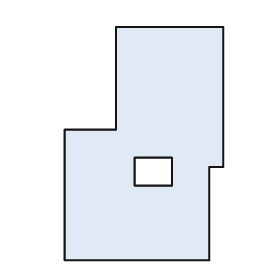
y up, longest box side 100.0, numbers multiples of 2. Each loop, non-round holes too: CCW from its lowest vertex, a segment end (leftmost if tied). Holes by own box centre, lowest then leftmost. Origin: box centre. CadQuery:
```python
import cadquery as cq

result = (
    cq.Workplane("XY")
    .moveTo(-34.0, -50.0)
    .lineTo(28.0, -50.0)
    .lineTo(28.0, -10.0)
    .lineTo(34.0, -10.0)
    .lineTo(34.0, 50.0)
    .lineTo(-12.0, 50.0)
    .lineTo(-12.0, 6.0)
    .lineTo(-34.0, 6.0)
    .close()
    .moveTo(-4.0, -18.0)
    .lineTo(12.0, -18.0)
    .lineTo(12.0, -6.0)
    .lineTo(-4.0, -6.0)
    .close()
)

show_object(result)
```